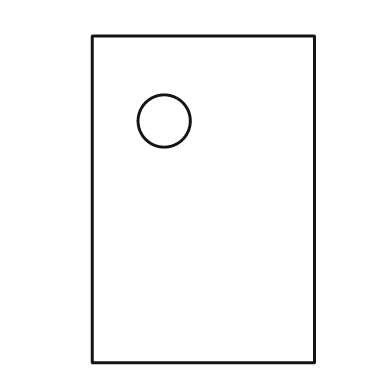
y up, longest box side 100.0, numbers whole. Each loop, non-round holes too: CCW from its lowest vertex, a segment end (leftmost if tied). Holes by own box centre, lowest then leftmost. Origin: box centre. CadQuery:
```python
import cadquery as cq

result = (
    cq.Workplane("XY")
    .moveTo(-34.0, -50.0)
    .lineTo(34.0, -50.0)
    .lineTo(34.0, 50.0)
    .lineTo(-34.0, 50.0)
    .close()
    .moveTo(-12.0, 24.0)
    .circle(8.0)
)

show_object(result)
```